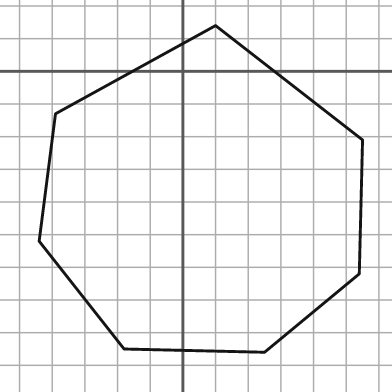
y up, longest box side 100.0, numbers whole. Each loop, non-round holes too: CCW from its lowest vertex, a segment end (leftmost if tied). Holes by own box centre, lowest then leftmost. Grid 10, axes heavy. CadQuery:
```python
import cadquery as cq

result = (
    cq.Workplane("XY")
    .moveTo(25.0, -86.0)
    .lineTo(54.0, -62.0)
    .lineTo(55.0, -21.0)
    .lineTo(10.0, 14.0)
    .lineTo(-39.0, -13.0)
    .lineTo(-44.0, -52.0)
    .lineTo(-18.0, -85.0)
    .close()
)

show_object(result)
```